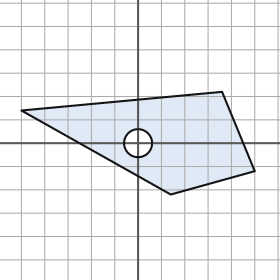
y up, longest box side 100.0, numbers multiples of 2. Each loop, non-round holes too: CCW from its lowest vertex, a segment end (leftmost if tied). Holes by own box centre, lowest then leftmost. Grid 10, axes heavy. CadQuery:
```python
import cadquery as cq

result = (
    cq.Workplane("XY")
    .moveTo(14.0, -22.0)
    .lineTo(50.0, -12.0)
    .lineTo(36.0, 22.0)
    .lineTo(-50.0, 14.0)
    .close()
    .moveTo(0.0, 0.0)
    .circle(6.0)
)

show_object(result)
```